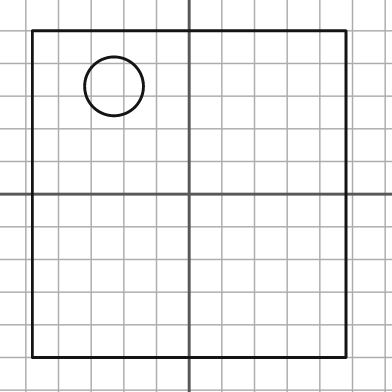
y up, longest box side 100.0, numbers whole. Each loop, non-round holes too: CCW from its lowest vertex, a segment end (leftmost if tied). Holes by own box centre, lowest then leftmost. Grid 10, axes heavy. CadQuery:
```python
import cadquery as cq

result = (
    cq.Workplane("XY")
    .moveTo(-48.0, -50.0)
    .lineTo(48.0, -50.0)
    .lineTo(48.0, 50.0)
    .lineTo(-48.0, 50.0)
    .close()
    .moveTo(-23.0, 33.0)
    .circle(9.0)
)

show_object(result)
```